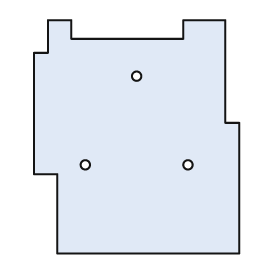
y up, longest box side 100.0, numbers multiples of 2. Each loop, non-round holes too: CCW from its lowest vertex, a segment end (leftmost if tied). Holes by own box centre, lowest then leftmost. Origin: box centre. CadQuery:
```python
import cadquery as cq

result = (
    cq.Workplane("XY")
    .moveTo(-34.0, -50.0)
    .lineTo(44.0, -50.0)
    .lineTo(44.0, 6.0)
    .lineTo(38.0, 6.0)
    .lineTo(38.0, 50.0)
    .lineTo(20.0, 50.0)
    .lineTo(20.0, 42.0)
    .lineTo(-28.0, 42.0)
    .lineTo(-28.0, 50.0)
    .lineTo(-38.0, 50.0)
    .lineTo(-38.0, 36.0)
    .lineTo(-44.0, 36.0)
    .lineTo(-44.0, -16.0)
    .lineTo(-34.0, -16.0)
    .close()
    .moveTo(-22.0, -12.0)
    .circle(2.0)
    .moveTo(22.0, -12.0)
    .circle(2.0)
    .moveTo(0.0, 26.0)
    .circle(2.0)
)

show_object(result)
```